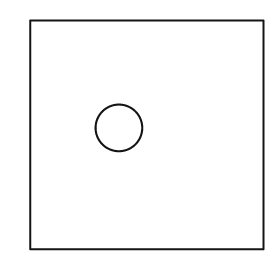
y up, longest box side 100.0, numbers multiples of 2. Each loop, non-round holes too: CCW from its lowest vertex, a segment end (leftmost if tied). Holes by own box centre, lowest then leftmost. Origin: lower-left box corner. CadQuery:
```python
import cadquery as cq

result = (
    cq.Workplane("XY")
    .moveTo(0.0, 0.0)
    .lineTo(100.0, 0.0)
    .lineTo(100.0, 98.0)
    .lineTo(0.0, 98.0)
    .close()
    .moveTo(38.0, 52.0)
    .circle(10.0)
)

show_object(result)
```